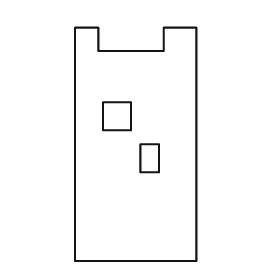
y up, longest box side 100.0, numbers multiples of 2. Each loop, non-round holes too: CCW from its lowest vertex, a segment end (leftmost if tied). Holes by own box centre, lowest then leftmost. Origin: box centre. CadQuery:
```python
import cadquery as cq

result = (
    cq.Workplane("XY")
    .moveTo(-26.0, -50.0)
    .lineTo(26.0, -50.0)
    .lineTo(26.0, 50.0)
    .lineTo(12.0, 50.0)
    .lineTo(12.0, 40.0)
    .lineTo(-16.0, 40.0)
    .lineTo(-16.0, 50.0)
    .lineTo(-26.0, 50.0)
    .close()
    .moveTo(2.0, -12.0)
    .lineTo(10.0, -12.0)
    .lineTo(10.0, 0.0)
    .lineTo(2.0, 0.0)
    .close()
    .moveTo(-14.0, 6.0)
    .lineTo(-2.0, 6.0)
    .lineTo(-2.0, 18.0)
    .lineTo(-14.0, 18.0)
    .close()
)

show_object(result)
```